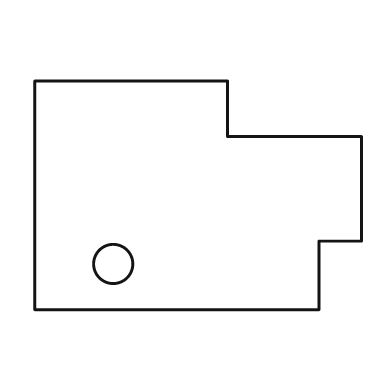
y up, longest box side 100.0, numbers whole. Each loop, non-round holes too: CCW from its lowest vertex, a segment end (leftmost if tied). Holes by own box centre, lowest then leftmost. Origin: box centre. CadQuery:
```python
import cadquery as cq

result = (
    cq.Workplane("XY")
    .moveTo(-50.0, -35.0)
    .lineTo(37.0, -35.0)
    .lineTo(37.0, -14.0)
    .lineTo(50.0, -14.0)
    .lineTo(50.0, 18.0)
    .lineTo(9.0, 18.0)
    .lineTo(9.0, 35.0)
    .lineTo(-50.0, 35.0)
    .close()
    .moveTo(-26.0, -21.0)
    .circle(6.0)
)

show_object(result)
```